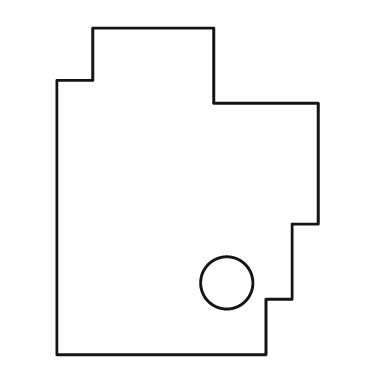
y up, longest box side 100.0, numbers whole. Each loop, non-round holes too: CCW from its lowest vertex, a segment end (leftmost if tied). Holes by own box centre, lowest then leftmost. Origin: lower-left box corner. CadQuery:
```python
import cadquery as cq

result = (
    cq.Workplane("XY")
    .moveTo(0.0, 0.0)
    .lineTo(64.0, 0.0)
    .lineTo(64.0, 17.0)
    .lineTo(72.0, 17.0)
    .lineTo(72.0, 40.0)
    .lineTo(80.0, 40.0)
    .lineTo(80.0, 77.0)
    .lineTo(48.0, 77.0)
    .lineTo(48.0, 100.0)
    .lineTo(11.0, 100.0)
    .lineTo(11.0, 84.0)
    .lineTo(0.0, 84.0)
    .close()
    .moveTo(52.0, 22.0)
    .circle(8.0)
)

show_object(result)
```